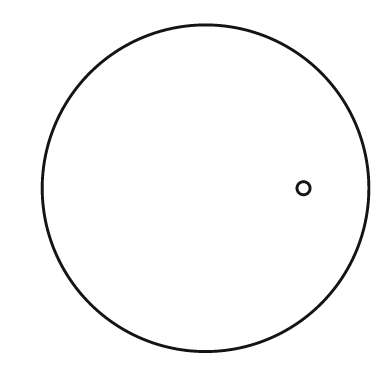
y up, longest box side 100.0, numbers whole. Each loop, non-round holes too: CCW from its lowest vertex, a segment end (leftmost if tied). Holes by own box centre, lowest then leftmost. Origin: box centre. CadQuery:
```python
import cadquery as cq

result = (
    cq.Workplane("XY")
    .moveTo(0.0, 0.0)
    .circle(50.0)
    .moveTo(30.0, 0.0)
    .circle(2.0)
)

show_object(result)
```